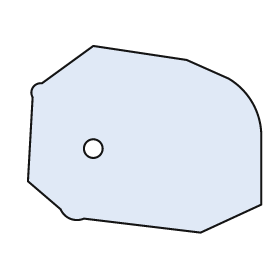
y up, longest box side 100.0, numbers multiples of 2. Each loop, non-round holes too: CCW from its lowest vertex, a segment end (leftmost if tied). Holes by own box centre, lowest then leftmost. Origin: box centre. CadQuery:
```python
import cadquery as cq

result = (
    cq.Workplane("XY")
    .moveTo(24.0, -40.0)
    .lineTo(50.0, -28.0)
    .lineTo(50.0, 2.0)
    .threePointArc((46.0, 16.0), (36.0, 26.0))
    .lineTo(18.0, 34.0)
    .lineTo(-22.0, 40.0)
    .lineTo(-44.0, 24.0)
    .threePointArc((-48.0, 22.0), (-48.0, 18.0))
    .lineTo(-50.0, -18.0)
    .lineTo(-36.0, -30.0)
    .threePointArc((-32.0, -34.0), (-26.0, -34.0))
    .close()
    .moveTo(-22.0, -4.0)
    .circle(4.0)
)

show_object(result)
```